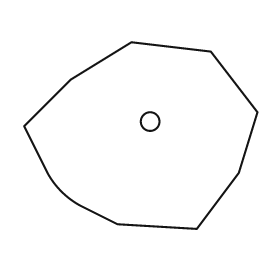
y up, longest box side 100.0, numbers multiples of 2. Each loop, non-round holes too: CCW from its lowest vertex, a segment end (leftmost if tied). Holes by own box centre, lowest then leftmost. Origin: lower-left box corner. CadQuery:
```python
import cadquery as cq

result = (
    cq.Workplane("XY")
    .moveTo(74.0, 0.0)
    .lineTo(92.0, 24.0)
    .lineTo(100.0, 50.0)
    .lineTo(80.0, 76.0)
    .lineTo(46.0, 80.0)
    .lineTo(20.0, 64.0)
    .lineTo(0.0, 44.0)
    .lineTo(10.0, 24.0)
    .threePointArc((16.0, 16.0), (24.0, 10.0))
    .lineTo(40.0, 2.0)
    .close()
    .moveTo(54.0, 46.0)
    .circle(4.0)
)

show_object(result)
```